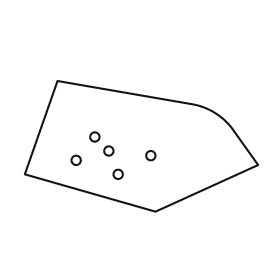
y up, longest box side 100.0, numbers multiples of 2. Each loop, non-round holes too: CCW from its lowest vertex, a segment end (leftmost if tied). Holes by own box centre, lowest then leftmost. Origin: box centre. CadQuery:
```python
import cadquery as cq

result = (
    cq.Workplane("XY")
    .moveTo(6.0, -28.0)
    .lineTo(50.0, -8.0)
    .lineTo(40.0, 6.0)
    .threePointArc((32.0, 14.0), (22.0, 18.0))
    .lineTo(-36.0, 28.0)
    .lineTo(-50.0, -12.0)
    .close()
    .moveTo(-10.0, -12.0)
    .circle(2.0)
    .moveTo(-28.0, -6.0)
    .circle(2.0)
    .moveTo(4.0, -4.0)
    .circle(2.0)
    .moveTo(-14.0, -2.0)
    .circle(2.0)
    .moveTo(-20.0, 4.0)
    .circle(2.0)
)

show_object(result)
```